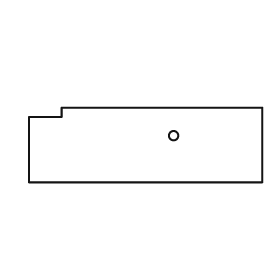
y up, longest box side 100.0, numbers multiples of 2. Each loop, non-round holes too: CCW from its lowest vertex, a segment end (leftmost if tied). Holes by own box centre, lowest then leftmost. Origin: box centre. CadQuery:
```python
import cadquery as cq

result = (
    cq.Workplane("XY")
    .moveTo(-50.0, -16.0)
    .lineTo(50.0, -16.0)
    .lineTo(50.0, 16.0)
    .lineTo(-36.0, 16.0)
    .lineTo(-36.0, 12.0)
    .lineTo(-50.0, 12.0)
    .close()
    .moveTo(12.0, 4.0)
    .circle(2.0)
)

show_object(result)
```